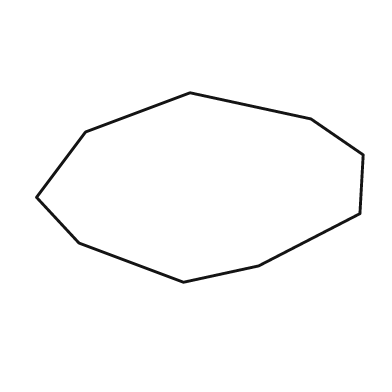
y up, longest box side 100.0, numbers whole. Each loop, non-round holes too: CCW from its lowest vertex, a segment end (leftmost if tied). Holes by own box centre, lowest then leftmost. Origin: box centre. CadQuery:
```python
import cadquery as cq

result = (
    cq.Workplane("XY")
    .moveTo(-5.0, -29.0)
    .lineTo(18.0, -24.0)
    .lineTo(49.0, -8.0)
    .lineTo(50.0, 10.0)
    .lineTo(34.0, 21.0)
    .lineTo(-3.0, 29.0)
    .lineTo(-35.0, 17.0)
    .lineTo(-50.0, -3.0)
    .lineTo(-37.0, -17.0)
    .close()
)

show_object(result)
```